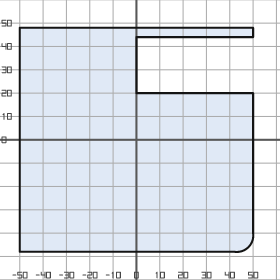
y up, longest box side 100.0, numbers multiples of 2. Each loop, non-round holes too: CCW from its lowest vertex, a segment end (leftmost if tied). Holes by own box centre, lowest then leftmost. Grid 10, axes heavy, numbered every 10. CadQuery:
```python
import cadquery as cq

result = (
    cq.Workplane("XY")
    .moveTo(-50.0, -48.0)
    .lineTo(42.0, -48.0)
    .threePointArc((48.0, -46.0), (50.0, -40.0))
    .lineTo(50.0, 20.0)
    .lineTo(0.0, 20.0)
    .lineTo(0.0, 44.0)
    .lineTo(50.0, 44.0)
    .lineTo(50.0, 48.0)
    .lineTo(-50.0, 48.0)
    .close()
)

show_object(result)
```